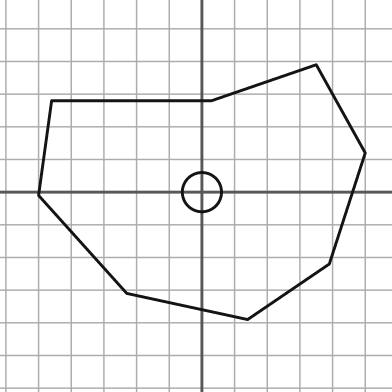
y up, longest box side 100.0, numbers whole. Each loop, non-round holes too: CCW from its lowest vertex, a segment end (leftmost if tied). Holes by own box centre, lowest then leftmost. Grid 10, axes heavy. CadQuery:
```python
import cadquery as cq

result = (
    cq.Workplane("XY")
    .moveTo(14.0, -39.0)
    .lineTo(39.0, -22.0)
    .lineTo(50.0, 12.0)
    .lineTo(35.0, 39.0)
    .lineTo(3.0, 28.0)
    .lineTo(-46.0, 28.0)
    .lineTo(-50.0, -1.0)
    .lineTo(-23.0, -31.0)
    .close()
    .moveTo(0.0, 0.0)
    .circle(6.0)
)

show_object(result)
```